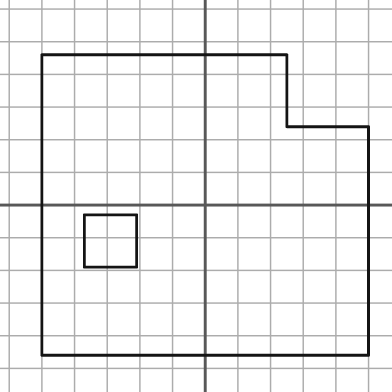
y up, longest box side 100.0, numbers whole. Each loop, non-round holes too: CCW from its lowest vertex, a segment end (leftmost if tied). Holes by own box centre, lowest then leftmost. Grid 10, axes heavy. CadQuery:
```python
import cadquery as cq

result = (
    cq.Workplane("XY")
    .moveTo(-50.0, -46.0)
    .lineTo(50.0, -46.0)
    .lineTo(50.0, 24.0)
    .lineTo(25.0, 24.0)
    .lineTo(25.0, 46.0)
    .lineTo(-50.0, 46.0)
    .close()
    .moveTo(-37.0, -19.0)
    .lineTo(-21.0, -19.0)
    .lineTo(-21.0, -3.0)
    .lineTo(-37.0, -3.0)
    .close()
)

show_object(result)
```